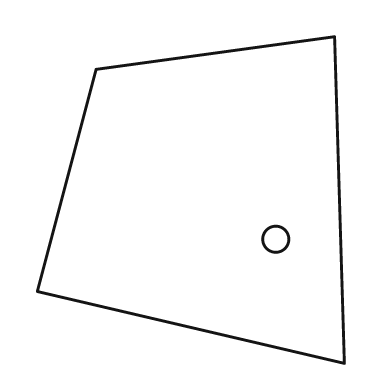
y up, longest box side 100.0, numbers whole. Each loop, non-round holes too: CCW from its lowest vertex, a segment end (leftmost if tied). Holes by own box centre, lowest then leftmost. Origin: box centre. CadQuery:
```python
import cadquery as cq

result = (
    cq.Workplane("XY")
    .moveTo(47.0, -50.0)
    .lineTo(44.0, 50.0)
    .lineTo(-29.0, 40.0)
    .lineTo(-47.0, -28.0)
    .close()
    .moveTo(26.0, -12.0)
    .circle(4.0)
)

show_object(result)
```